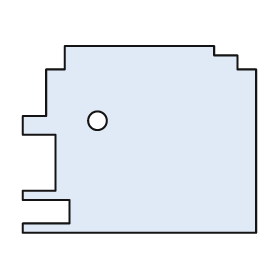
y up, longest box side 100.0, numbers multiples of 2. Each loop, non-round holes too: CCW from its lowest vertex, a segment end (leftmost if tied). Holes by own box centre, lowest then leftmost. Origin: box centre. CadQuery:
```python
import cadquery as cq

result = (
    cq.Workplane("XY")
    .moveTo(-50.0, -40.0)
    .lineTo(50.0, -40.0)
    .lineTo(50.0, 30.0)
    .lineTo(42.0, 30.0)
    .lineTo(42.0, 36.0)
    .lineTo(32.0, 36.0)
    .lineTo(32.0, 40.0)
    .lineTo(-32.0, 40.0)
    .lineTo(-32.0, 30.0)
    .lineTo(-40.0, 30.0)
    .lineTo(-40.0, 10.0)
    .lineTo(-50.0, 10.0)
    .lineTo(-50.0, 2.0)
    .lineTo(-36.0, 2.0)
    .lineTo(-36.0, -22.0)
    .lineTo(-50.0, -22.0)
    .lineTo(-50.0, -26.0)
    .lineTo(-30.0, -26.0)
    .lineTo(-30.0, -36.0)
    .lineTo(-50.0, -36.0)
    .close()
    .moveTo(-18.0, 8.0)
    .circle(4.0)
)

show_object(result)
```